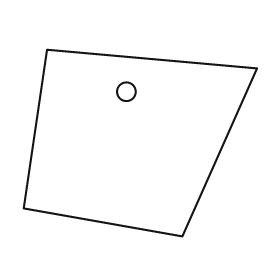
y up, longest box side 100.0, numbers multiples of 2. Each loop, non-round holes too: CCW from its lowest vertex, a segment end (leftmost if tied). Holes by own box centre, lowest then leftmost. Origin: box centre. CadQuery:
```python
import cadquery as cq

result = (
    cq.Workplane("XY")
    .moveTo(18.0, -40.0)
    .lineTo(50.0, 32.0)
    .lineTo(-40.0, 40.0)
    .lineTo(-50.0, -28.0)
    .close()
    .moveTo(-6.0, 22.0)
    .circle(4.0)
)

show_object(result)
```